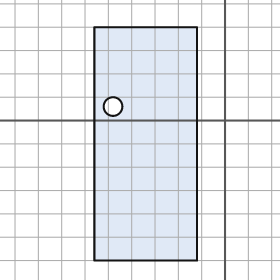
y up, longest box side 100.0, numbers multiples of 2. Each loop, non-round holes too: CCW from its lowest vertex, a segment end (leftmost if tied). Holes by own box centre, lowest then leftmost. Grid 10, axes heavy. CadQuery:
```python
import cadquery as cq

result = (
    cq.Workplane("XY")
    .moveTo(-56.0, -60.0)
    .lineTo(-12.0, -60.0)
    .lineTo(-12.0, 40.0)
    .lineTo(-56.0, 40.0)
    .close()
    .moveTo(-48.0, 6.0)
    .circle(4.0)
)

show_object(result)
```